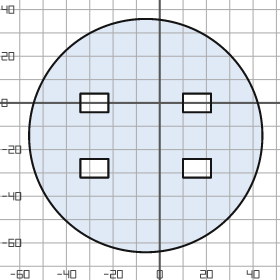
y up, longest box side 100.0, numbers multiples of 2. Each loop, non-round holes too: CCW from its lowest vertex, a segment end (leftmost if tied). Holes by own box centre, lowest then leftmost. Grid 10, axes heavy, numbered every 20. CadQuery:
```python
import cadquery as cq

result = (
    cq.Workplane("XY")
    .moveTo(-6.0, -14.0)
    .circle(50.0)
    .moveTo(-34.0, -32.0)
    .lineTo(-22.0, -32.0)
    .lineTo(-22.0, -24.0)
    .lineTo(-34.0, -24.0)
    .close()
    .moveTo(10.0, -32.0)
    .lineTo(22.0, -32.0)
    .lineTo(22.0, -24.0)
    .lineTo(10.0, -24.0)
    .close()
    .moveTo(-34.0, -4.0)
    .lineTo(-22.0, -4.0)
    .lineTo(-22.0, 4.0)
    .lineTo(-34.0, 4.0)
    .close()
    .moveTo(10.0, -4.0)
    .lineTo(22.0, -4.0)
    .lineTo(22.0, 4.0)
    .lineTo(10.0, 4.0)
    .close()
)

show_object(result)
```